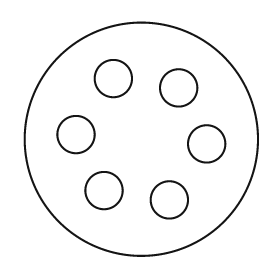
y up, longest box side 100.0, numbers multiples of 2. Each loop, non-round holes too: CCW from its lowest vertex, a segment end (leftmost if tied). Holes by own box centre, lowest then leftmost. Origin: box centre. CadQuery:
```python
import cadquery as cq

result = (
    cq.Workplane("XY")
    .moveTo(0.0, 0.0)
    .circle(50.0)
    .moveTo(12.0, -26.0)
    .circle(8.0)
    .moveTo(-16.0, -22.0)
    .circle(8.0)
    .moveTo(28.0, -2.0)
    .circle(8.0)
    .moveTo(-28.0, 2.0)
    .circle(8.0)
    .moveTo(16.0, 22.0)
    .circle(8.0)
    .moveTo(-12.0, 26.0)
    .circle(8.0)
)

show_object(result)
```